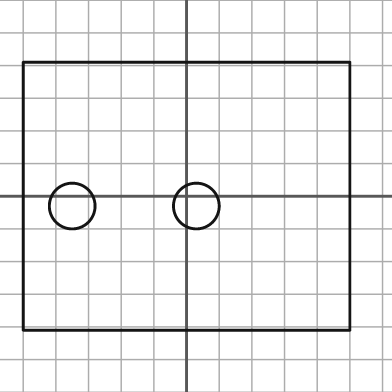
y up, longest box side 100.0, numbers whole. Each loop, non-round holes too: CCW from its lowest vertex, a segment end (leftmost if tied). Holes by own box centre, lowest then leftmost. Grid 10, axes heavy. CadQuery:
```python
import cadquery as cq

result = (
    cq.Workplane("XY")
    .moveTo(-50.0, -41.0)
    .lineTo(50.0, -41.0)
    .lineTo(50.0, 41.0)
    .lineTo(-50.0, 41.0)
    .close()
    .moveTo(-35.0, -3.0)
    .circle(7.0)
    .moveTo(3.0, -3.0)
    .circle(7.0)
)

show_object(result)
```